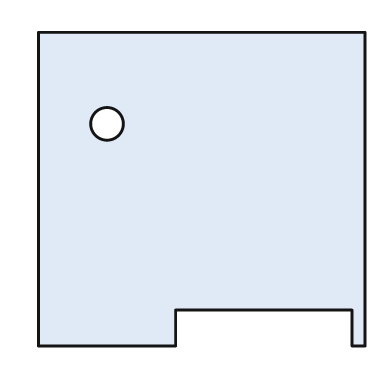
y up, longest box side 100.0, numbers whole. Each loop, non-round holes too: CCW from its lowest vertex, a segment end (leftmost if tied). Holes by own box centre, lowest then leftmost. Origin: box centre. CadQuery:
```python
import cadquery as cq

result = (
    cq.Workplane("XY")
    .moveTo(-50.0, -48.0)
    .lineTo(-8.0, -48.0)
    .lineTo(-8.0, -37.0)
    .lineTo(46.0, -37.0)
    .lineTo(46.0, -48.0)
    .lineTo(50.0, -48.0)
    .lineTo(50.0, 48.0)
    .lineTo(-50.0, 48.0)
    .close()
    .moveTo(-29.0, 20.0)
    .circle(5.0)
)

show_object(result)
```